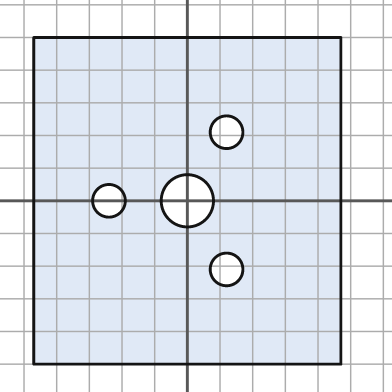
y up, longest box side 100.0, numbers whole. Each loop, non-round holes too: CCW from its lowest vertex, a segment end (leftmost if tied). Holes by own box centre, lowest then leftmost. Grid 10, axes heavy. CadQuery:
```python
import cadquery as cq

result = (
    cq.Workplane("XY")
    .moveTo(-47.0, -50.0)
    .lineTo(47.0, -50.0)
    .lineTo(47.0, 50.0)
    .lineTo(-47.0, 50.0)
    .close()
    .moveTo(12.0, -21.0)
    .circle(5.0)
    .moveTo(-24.0, 0.0)
    .circle(5.0)
    .moveTo(0.0, 0.0)
    .circle(8.0)
    .moveTo(12.0, 21.0)
    .circle(5.0)
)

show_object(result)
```